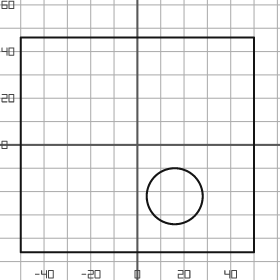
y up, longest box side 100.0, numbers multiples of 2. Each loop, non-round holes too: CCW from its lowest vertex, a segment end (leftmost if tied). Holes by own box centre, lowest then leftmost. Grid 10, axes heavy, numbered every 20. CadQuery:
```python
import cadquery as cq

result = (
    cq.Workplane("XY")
    .moveTo(-50.0, -46.0)
    .lineTo(50.0, -46.0)
    .lineTo(50.0, 46.0)
    .lineTo(-50.0, 46.0)
    .close()
    .moveTo(16.0, -22.0)
    .circle(12.0)
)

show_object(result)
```